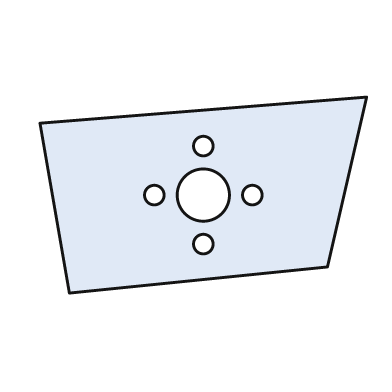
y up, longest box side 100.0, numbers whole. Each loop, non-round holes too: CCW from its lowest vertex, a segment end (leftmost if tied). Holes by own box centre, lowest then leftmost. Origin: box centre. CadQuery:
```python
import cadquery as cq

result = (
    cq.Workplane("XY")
    .moveTo(-41.0, -30.0)
    .lineTo(38.0, -22.0)
    .lineTo(50.0, 30.0)
    .lineTo(-50.0, 22.0)
    .close()
    .moveTo(0.0, -15.0)
    .circle(3.0)
    .moveTo(-15.0, 0.0)
    .circle(3.0)
    .moveTo(0.0, 0.0)
    .circle(8.0)
    .moveTo(15.0, 0.0)
    .circle(3.0)
    .moveTo(0.0, 15.0)
    .circle(3.0)
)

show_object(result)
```